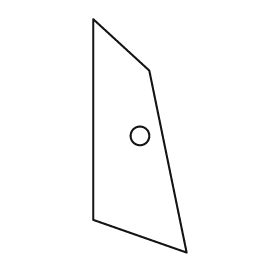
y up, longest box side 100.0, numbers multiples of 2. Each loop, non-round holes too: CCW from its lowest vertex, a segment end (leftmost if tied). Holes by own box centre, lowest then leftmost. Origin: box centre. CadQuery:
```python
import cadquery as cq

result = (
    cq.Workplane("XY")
    .moveTo(20.0, -50.0)
    .lineTo(4.0, 28.0)
    .lineTo(-20.0, 50.0)
    .lineTo(-20.0, -36.0)
    .close()
    .moveTo(0.0, 0.0)
    .circle(4.0)
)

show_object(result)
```